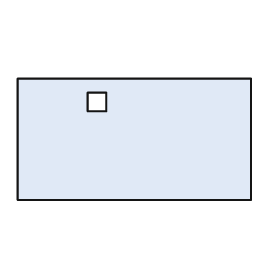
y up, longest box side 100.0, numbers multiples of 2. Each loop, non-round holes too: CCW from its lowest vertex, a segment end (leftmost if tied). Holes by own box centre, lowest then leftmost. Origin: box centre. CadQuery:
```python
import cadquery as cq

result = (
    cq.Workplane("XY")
    .moveTo(-50.0, -26.0)
    .lineTo(50.0, -26.0)
    .lineTo(50.0, 26.0)
    .lineTo(-50.0, 26.0)
    .close()
    .moveTo(-20.0, 12.0)
    .lineTo(-12.0, 12.0)
    .lineTo(-12.0, 20.0)
    .lineTo(-20.0, 20.0)
    .close()
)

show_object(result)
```